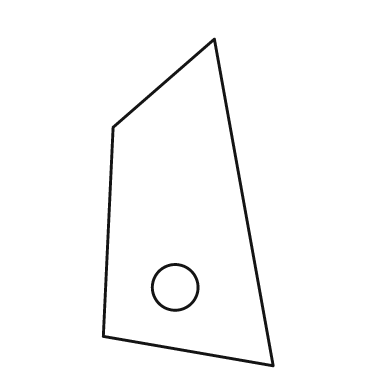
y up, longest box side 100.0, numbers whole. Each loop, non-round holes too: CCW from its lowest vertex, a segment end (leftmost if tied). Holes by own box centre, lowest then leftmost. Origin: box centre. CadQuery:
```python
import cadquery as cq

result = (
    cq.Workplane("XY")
    .moveTo(26.0, -50.0)
    .lineTo(8.0, 50.0)
    .lineTo(-23.0, 23.0)
    .lineTo(-26.0, -41.0)
    .close()
    .moveTo(-4.0, -26.0)
    .circle(7.0)
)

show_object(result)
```